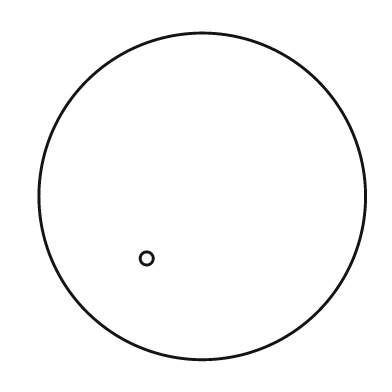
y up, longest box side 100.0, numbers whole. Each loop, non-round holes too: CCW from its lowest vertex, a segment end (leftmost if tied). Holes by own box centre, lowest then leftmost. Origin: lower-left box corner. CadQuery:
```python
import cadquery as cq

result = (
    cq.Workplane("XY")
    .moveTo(50.0, 50.0)
    .circle(50.0)
    .moveTo(33.0, 31.0)
    .circle(2.0)
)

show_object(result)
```